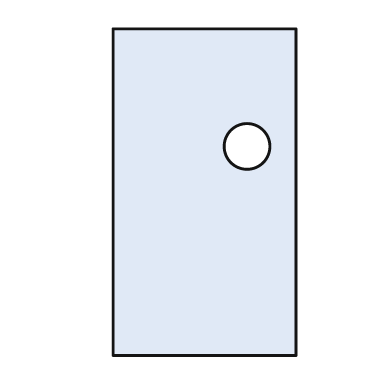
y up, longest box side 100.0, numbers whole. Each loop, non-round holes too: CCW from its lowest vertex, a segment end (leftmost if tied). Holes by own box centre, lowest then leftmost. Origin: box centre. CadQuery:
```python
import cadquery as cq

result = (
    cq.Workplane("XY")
    .moveTo(-28.0, -50.0)
    .lineTo(28.0, -50.0)
    .lineTo(28.0, 50.0)
    .lineTo(-28.0, 50.0)
    .close()
    .moveTo(13.0, 14.0)
    .circle(7.0)
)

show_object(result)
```